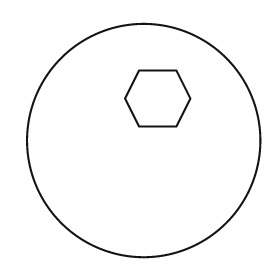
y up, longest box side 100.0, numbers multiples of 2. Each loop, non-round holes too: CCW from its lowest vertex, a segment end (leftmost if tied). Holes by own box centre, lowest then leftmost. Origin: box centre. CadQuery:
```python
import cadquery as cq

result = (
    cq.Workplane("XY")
    .moveTo(0.0, 0.0)
    .circle(50.0)
    .moveTo(-2.0, 6.0)
    .lineTo(14.0, 6.0)
    .lineTo(20.0, 18.0)
    .lineTo(14.0, 30.0)
    .lineTo(-2.0, 30.0)
    .lineTo(-8.0, 18.0)
    .close()
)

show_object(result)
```